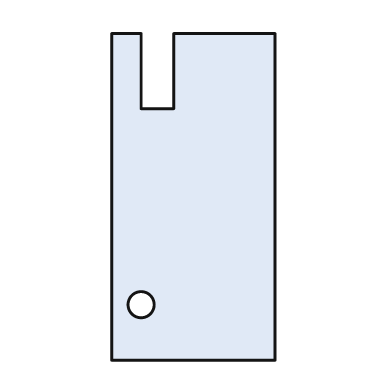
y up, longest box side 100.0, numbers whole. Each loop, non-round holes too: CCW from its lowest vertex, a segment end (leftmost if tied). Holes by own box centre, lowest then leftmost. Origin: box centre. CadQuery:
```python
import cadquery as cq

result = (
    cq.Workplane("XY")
    .moveTo(-25.0, -50.0)
    .lineTo(25.0, -50.0)
    .lineTo(25.0, 50.0)
    .lineTo(-6.0, 50.0)
    .lineTo(-6.0, 27.0)
    .lineTo(-16.0, 27.0)
    .lineTo(-16.0, 50.0)
    .lineTo(-25.0, 50.0)
    .close()
    .moveTo(-16.0, -33.0)
    .circle(4.0)
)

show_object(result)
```